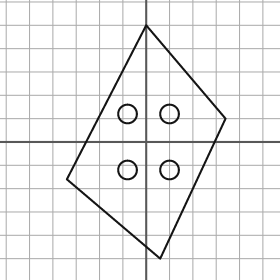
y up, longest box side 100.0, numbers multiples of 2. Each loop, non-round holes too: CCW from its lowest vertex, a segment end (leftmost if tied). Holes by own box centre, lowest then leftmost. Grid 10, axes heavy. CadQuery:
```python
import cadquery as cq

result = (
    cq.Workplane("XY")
    .moveTo(6.0, -50.0)
    .lineTo(34.0, 10.0)
    .lineTo(0.0, 50.0)
    .lineTo(-34.0, -16.0)
    .close()
    .moveTo(-8.0, -12.0)
    .circle(4.0)
    .moveTo(10.0, -12.0)
    .circle(4.0)
    .moveTo(-8.0, 12.0)
    .circle(4.0)
    .moveTo(10.0, 12.0)
    .circle(4.0)
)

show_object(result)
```